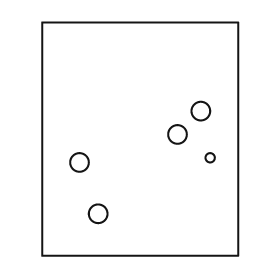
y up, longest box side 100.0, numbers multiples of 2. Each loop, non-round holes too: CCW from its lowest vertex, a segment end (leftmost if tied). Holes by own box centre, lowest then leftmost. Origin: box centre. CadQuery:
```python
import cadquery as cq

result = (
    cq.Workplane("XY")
    .moveTo(-42.0, -50.0)
    .lineTo(42.0, -50.0)
    .lineTo(42.0, 50.0)
    .lineTo(-42.0, 50.0)
    .close()
    .moveTo(-18.0, -32.0)
    .circle(4.0)
    .moveTo(-26.0, -10.0)
    .circle(4.0)
    .moveTo(30.0, -8.0)
    .circle(2.0)
    .moveTo(16.0, 2.0)
    .circle(4.0)
    .moveTo(26.0, 12.0)
    .circle(4.0)
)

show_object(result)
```